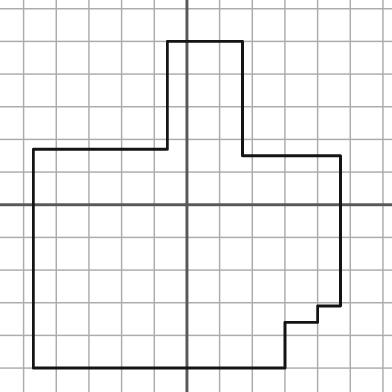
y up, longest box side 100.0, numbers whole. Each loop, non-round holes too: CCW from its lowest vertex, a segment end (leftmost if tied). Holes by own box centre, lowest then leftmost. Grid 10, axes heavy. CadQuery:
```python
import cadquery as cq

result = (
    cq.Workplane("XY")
    .moveTo(-47.0, -50.0)
    .lineTo(30.0, -50.0)
    .lineTo(30.0, -36.0)
    .lineTo(40.0, -36.0)
    .lineTo(40.0, -31.0)
    .lineTo(47.0, -31.0)
    .lineTo(47.0, 15.0)
    .lineTo(17.0, 15.0)
    .lineTo(17.0, 50.0)
    .lineTo(-6.0, 50.0)
    .lineTo(-6.0, 17.0)
    .lineTo(-47.0, 17.0)
    .close()
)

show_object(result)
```